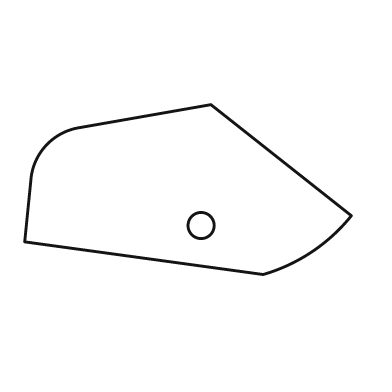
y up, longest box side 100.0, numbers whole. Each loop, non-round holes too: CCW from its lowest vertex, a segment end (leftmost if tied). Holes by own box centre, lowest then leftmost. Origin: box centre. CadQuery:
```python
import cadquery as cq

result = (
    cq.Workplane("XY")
    .moveTo(23.0, -26.0)
    .threePointArc((38.0, -19.0), (50.0, -8.0))
    .lineTo(7.0, 26.0)
    .lineTo(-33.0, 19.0)
    .threePointArc((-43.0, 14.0), (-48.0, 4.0))
    .lineTo(-50.0, -16.0)
    .close()
    .moveTo(4.0, -11.0)
    .circle(4.0)
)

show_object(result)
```